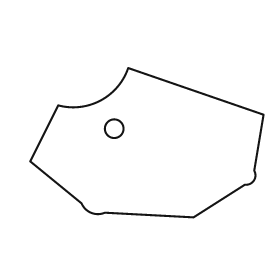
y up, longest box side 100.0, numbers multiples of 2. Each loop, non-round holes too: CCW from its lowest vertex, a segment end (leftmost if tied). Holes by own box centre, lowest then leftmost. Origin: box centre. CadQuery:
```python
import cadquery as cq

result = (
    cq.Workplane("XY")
    .moveTo(20.0, -32.0)
    .lineTo(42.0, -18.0)
    .threePointArc((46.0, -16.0), (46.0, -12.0))
    .lineTo(50.0, 12.0)
    .lineTo(-8.0, 32.0)
    .threePointArc((-20.0, 18.0), (-38.0, 16.0))
    .lineTo(-50.0, -8.0)
    .lineTo(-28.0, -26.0)
    .threePointArc((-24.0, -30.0), (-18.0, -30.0))
    .close()
    .moveTo(-14.0, 6.0)
    .circle(4.0)
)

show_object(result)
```